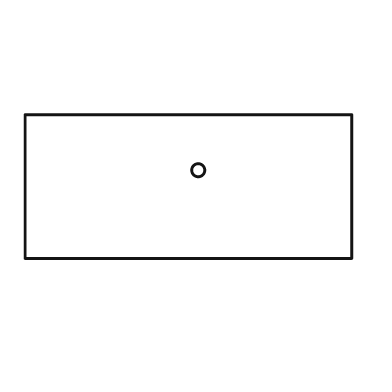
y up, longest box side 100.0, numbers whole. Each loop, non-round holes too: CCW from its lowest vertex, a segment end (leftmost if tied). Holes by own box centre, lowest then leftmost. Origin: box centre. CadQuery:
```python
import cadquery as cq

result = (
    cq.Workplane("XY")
    .moveTo(-50.0, -22.0)
    .lineTo(50.0, -22.0)
    .lineTo(50.0, 22.0)
    .lineTo(-50.0, 22.0)
    .close()
    .moveTo(3.0, 5.0)
    .circle(2.0)
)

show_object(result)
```